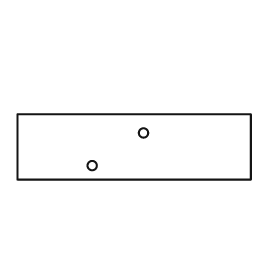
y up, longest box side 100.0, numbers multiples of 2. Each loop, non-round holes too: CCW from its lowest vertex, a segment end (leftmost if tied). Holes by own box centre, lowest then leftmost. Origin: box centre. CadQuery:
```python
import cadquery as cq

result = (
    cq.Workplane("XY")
    .moveTo(-50.0, -14.0)
    .lineTo(50.0, -14.0)
    .lineTo(50.0, 14.0)
    .lineTo(-50.0, 14.0)
    .close()
    .moveTo(-18.0, -8.0)
    .circle(2.0)
    .moveTo(4.0, 6.0)
    .circle(2.0)
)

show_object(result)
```